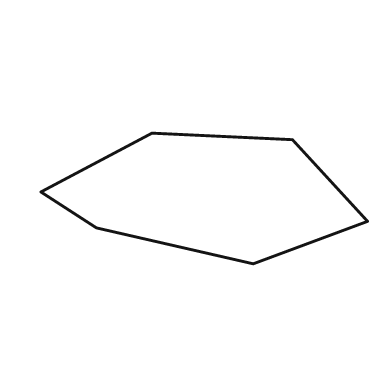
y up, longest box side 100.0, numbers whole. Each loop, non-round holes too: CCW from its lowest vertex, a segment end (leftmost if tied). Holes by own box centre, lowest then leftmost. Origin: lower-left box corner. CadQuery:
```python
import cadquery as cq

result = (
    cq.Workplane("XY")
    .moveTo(65.0, 0.0)
    .lineTo(100.0, 13.0)
    .lineTo(77.0, 38.0)
    .lineTo(34.0, 40.0)
    .lineTo(0.0, 22.0)
    .lineTo(17.0, 11.0)
    .close()
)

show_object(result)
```